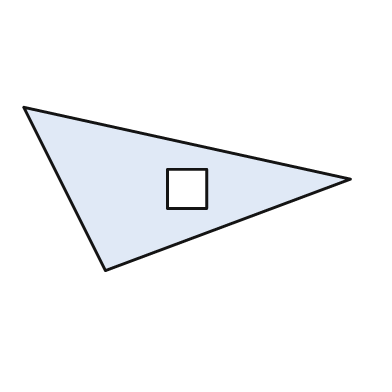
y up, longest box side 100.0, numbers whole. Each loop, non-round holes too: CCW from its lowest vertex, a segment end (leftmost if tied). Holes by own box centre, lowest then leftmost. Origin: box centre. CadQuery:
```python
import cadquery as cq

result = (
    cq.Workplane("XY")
    .moveTo(-25.0, -25.0)
    .lineTo(50.0, 3.0)
    .lineTo(-50.0, 25.0)
    .close()
    .moveTo(-6.0, -6.0)
    .lineTo(6.0, -6.0)
    .lineTo(6.0, 6.0)
    .lineTo(-6.0, 6.0)
    .close()
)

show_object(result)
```